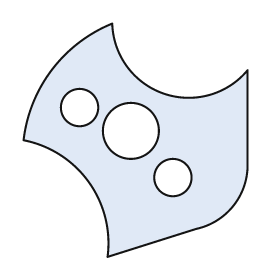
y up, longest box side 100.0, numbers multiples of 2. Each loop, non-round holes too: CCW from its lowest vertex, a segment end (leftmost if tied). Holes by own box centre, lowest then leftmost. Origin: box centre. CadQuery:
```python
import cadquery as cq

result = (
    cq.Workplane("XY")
    .moveTo(-12.0, -50.0)
    .lineTo(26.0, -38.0)
    .threePointArc((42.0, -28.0), (48.0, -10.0))
    .lineTo(48.0, 30.0)
    .threePointArc((12.0, 20.0), (-10.0, 50.0))
    .threePointArc((-36.0, 30.0), (-48.0, 0.0))
    .threePointArc((-20.0, -18.0), (-12.0, -50.0))
    .close()
    .moveTo(16.0, -16.0)
    .circle(8.0)
    .moveTo(-2.0, 4.0)
    .circle(12.0)
    .moveTo(-24.0, 14.0)
    .circle(8.0)
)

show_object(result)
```